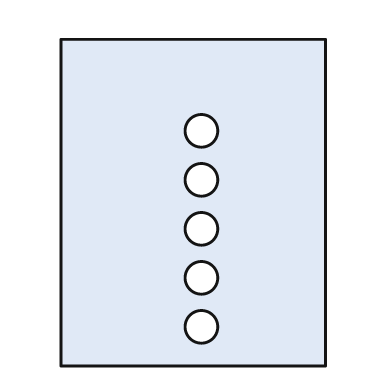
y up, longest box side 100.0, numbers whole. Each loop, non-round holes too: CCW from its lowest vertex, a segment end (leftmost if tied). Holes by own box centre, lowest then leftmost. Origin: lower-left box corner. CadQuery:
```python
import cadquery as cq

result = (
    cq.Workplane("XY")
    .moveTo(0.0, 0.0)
    .lineTo(81.0, 0.0)
    .lineTo(81.0, 100.0)
    .lineTo(0.0, 100.0)
    .close()
    .moveTo(43.0, 12.0)
    .circle(5.0)
    .moveTo(43.0, 27.0)
    .circle(5.0)
    .moveTo(43.0, 42.0)
    .circle(5.0)
    .moveTo(43.0, 57.0)
    .circle(5.0)
    .moveTo(43.0, 72.0)
    .circle(5.0)
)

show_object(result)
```